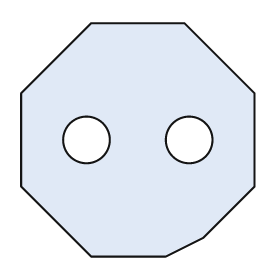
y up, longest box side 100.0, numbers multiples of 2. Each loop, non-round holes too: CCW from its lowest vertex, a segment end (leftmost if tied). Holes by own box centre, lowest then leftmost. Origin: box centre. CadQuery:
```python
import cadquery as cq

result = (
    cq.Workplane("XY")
    .moveTo(-20.0, -50.0)
    .lineTo(12.0, -50.0)
    .lineTo(28.0, -42.0)
    .lineTo(50.0, -20.0)
    .lineTo(50.0, 20.0)
    .lineTo(20.0, 50.0)
    .lineTo(-20.0, 50.0)
    .lineTo(-50.0, 20.0)
    .lineTo(-50.0, -20.0)
    .close()
    .moveTo(-22.0, 0.0)
    .circle(10.0)
    .moveTo(22.0, 0.0)
    .circle(10.0)
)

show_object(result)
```